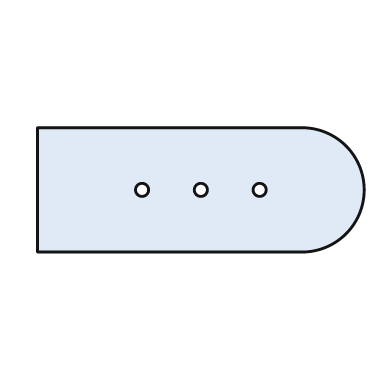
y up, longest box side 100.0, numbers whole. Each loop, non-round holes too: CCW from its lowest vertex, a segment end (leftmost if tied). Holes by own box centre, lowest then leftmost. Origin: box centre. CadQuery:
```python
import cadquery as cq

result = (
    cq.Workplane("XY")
    .moveTo(-50.0, -19.0)
    .lineTo(32.0, -19.0)
    .threePointArc((50.0, 0.0), (32.0, 19.0))
    .lineTo(-50.0, 19.0)
    .close()
    .moveTo(-18.0, 0.0)
    .circle(2.0)
    .moveTo(0.0, 0.0)
    .circle(2.0)
    .moveTo(18.0, 0.0)
    .circle(2.0)
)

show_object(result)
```